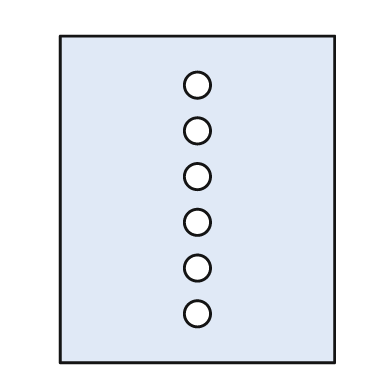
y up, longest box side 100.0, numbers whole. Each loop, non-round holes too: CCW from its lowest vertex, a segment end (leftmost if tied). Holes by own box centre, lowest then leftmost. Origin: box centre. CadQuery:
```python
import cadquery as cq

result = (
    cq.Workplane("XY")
    .moveTo(-42.0, -50.0)
    .lineTo(42.0, -50.0)
    .lineTo(42.0, 50.0)
    .lineTo(-42.0, 50.0)
    .close()
    .moveTo(0.0, -35.0)
    .circle(4.0)
    .moveTo(0.0, -21.0)
    .circle(4.0)
    .moveTo(0.0, -7.0)
    .circle(4.0)
    .moveTo(0.0, 7.0)
    .circle(4.0)
    .moveTo(0.0, 21.0)
    .circle(4.0)
    .moveTo(0.0, 35.0)
    .circle(4.0)
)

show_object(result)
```